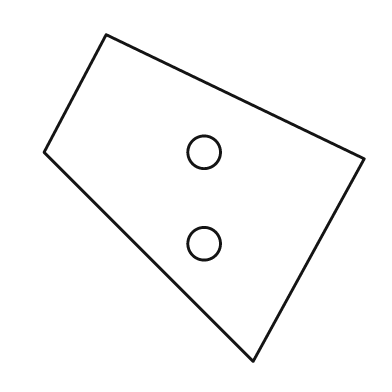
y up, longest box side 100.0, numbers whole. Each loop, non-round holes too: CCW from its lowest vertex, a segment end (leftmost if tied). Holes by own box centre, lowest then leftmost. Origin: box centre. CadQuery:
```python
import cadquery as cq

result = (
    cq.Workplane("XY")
    .moveTo(15.0, -50.0)
    .lineTo(49.0, 12.0)
    .lineTo(-30.0, 50.0)
    .lineTo(-49.0, 14.0)
    .close()
    .moveTo(0.0, -14.0)
    .circle(5.0)
    .moveTo(0.0, 14.0)
    .circle(5.0)
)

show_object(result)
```